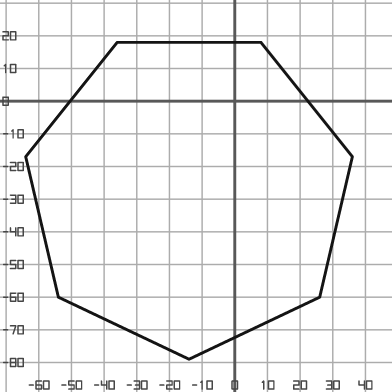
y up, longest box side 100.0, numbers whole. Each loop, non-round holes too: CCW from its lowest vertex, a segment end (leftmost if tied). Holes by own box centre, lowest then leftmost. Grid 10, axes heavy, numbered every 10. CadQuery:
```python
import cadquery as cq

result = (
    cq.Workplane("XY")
    .moveTo(-14.0, -79.0)
    .lineTo(26.0, -60.0)
    .lineTo(36.0, -17.0)
    .lineTo(8.0, 18.0)
    .lineTo(-36.0, 18.0)
    .lineTo(-64.0, -17.0)
    .lineTo(-54.0, -60.0)
    .close()
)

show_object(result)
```